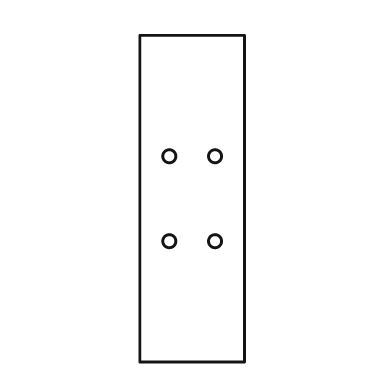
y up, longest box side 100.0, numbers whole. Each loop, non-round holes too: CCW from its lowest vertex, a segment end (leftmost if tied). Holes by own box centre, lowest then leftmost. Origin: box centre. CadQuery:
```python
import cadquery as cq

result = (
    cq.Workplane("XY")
    .moveTo(-16.0, -50.0)
    .lineTo(16.0, -50.0)
    .lineTo(16.0, 50.0)
    .lineTo(-16.0, 50.0)
    .close()
    .moveTo(-7.0, -13.0)
    .circle(2.0)
    .moveTo(7.0, -13.0)
    .circle(2.0)
    .moveTo(-7.0, 13.0)
    .circle(2.0)
    .moveTo(7.0, 13.0)
    .circle(2.0)
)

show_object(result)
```